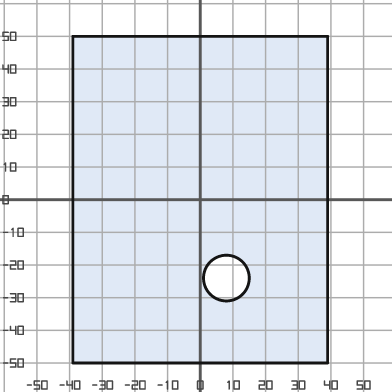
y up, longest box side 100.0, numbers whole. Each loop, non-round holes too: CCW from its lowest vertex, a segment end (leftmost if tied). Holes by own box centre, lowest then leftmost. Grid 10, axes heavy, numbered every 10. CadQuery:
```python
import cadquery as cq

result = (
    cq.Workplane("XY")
    .moveTo(-39.0, -50.0)
    .lineTo(39.0, -50.0)
    .lineTo(39.0, 50.0)
    .lineTo(-39.0, 50.0)
    .close()
    .moveTo(8.0, -24.0)
    .circle(7.0)
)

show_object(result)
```